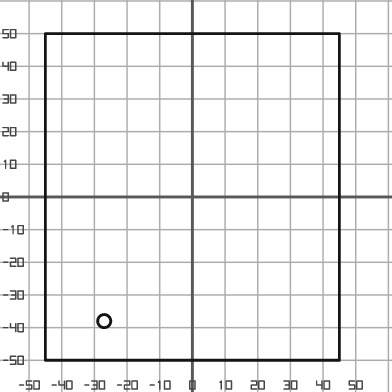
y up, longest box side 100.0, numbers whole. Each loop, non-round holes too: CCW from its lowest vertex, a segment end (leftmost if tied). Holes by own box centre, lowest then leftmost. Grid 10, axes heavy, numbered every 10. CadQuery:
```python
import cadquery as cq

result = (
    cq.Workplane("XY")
    .moveTo(-45.0, -50.0)
    .lineTo(45.0, -50.0)
    .lineTo(45.0, 50.0)
    .lineTo(-45.0, 50.0)
    .close()
    .moveTo(-27.0, -38.0)
    .circle(2.0)
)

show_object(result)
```